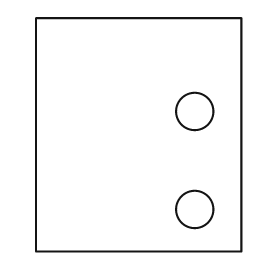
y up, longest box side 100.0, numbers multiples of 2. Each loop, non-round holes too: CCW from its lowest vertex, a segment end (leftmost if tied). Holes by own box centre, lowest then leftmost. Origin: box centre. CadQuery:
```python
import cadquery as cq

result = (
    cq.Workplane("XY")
    .moveTo(-44.0, -50.0)
    .lineTo(44.0, -50.0)
    .lineTo(44.0, 50.0)
    .lineTo(-44.0, 50.0)
    .close()
    .moveTo(24.0, -32.0)
    .circle(8.0)
    .moveTo(24.0, 10.0)
    .circle(8.0)
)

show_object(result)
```